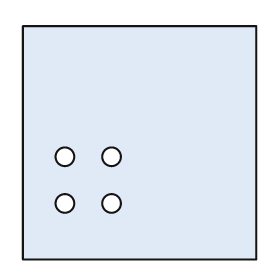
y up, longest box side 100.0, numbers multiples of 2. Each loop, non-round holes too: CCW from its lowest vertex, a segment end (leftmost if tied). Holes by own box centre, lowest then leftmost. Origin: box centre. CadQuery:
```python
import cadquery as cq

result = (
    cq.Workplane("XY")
    .moveTo(-50.0, -50.0)
    .lineTo(50.0, -50.0)
    .lineTo(50.0, 50.0)
    .lineTo(-50.0, 50.0)
    .close()
    .moveTo(-32.0, -26.0)
    .circle(4.0)
    .moveTo(-12.0, -26.0)
    .circle(4.0)
    .moveTo(-32.0, -6.0)
    .circle(4.0)
    .moveTo(-12.0, -6.0)
    .circle(4.0)
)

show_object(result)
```